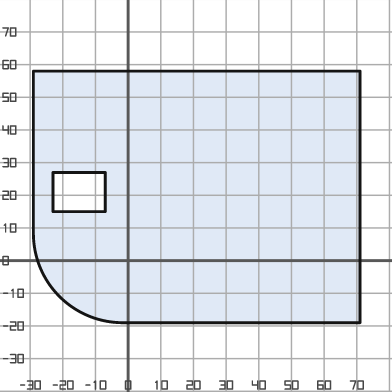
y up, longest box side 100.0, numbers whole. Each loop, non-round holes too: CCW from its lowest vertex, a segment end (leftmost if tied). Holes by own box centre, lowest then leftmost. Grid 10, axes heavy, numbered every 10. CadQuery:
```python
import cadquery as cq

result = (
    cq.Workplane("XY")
    .moveTo(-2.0, -19.0)
    .lineTo(71.0, -19.0)
    .lineTo(71.0, 58.0)
    .lineTo(-29.0, 58.0)
    .lineTo(-29.0, 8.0)
    .threePointArc((-21.0, -11.0), (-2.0, -19.0))
    .close()
    .moveTo(-23.0, 15.0)
    .lineTo(-7.0, 15.0)
    .lineTo(-7.0, 27.0)
    .lineTo(-23.0, 27.0)
    .close()
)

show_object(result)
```